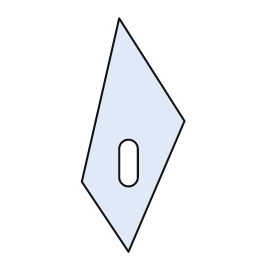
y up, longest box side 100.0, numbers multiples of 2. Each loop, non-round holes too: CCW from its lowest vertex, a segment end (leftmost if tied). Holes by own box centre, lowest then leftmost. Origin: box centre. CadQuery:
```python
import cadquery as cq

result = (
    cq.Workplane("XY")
    .moveTo(-2.0, -50.0)
    .lineTo(22.0, 6.0)
    .lineTo(-6.0, 50.0)
    .lineTo(-22.0, -20.0)
    .close()
    .moveTo(-6.0, -18.0)
    .threePointArc((-2.0, -22.0), (2.0, -18.0))
    .lineTo(2.0, -6.0)
    .threePointArc((-2.0, -2.0), (-6.0, -6.0))
    .close()
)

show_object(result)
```